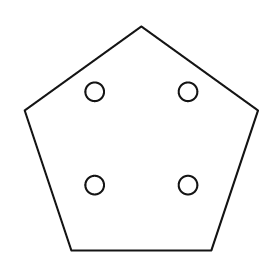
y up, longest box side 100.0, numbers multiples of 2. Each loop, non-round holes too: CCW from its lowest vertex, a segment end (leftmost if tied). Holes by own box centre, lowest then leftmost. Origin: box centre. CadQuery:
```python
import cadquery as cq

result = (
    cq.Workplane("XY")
    .moveTo(-30.0, -48.0)
    .lineTo(30.0, -48.0)
    .lineTo(50.0, 12.0)
    .lineTo(0.0, 48.0)
    .lineTo(-50.0, 12.0)
    .close()
    .moveTo(-20.0, -20.0)
    .circle(4.0)
    .moveTo(20.0, -20.0)
    .circle(4.0)
    .moveTo(-20.0, 20.0)
    .circle(4.0)
    .moveTo(20.0, 20.0)
    .circle(4.0)
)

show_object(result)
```